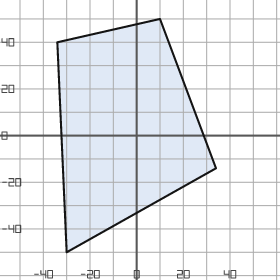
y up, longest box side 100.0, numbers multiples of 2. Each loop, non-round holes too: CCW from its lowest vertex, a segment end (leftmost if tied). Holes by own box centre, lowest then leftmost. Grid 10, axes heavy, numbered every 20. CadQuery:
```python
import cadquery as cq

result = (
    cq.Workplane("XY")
    .moveTo(-30.0, -50.0)
    .lineTo(34.0, -14.0)
    .lineTo(10.0, 50.0)
    .lineTo(-34.0, 40.0)
    .close()
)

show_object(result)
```